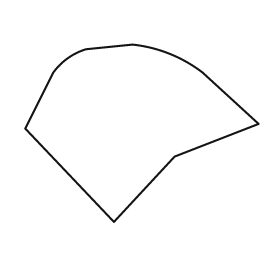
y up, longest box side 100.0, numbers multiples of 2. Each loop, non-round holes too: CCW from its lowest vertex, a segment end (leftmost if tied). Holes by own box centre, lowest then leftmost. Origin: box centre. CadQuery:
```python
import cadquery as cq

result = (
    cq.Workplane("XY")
    .moveTo(-12.0, -38.0)
    .lineTo(14.0, -10.0)
    .lineTo(50.0, 4.0)
    .lineTo(26.0, 26.0)
    .threePointArc((12.0, 34.0), (-4.0, 38.0))
    .lineTo(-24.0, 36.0)
    .threePointArc((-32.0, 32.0), (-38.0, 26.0))
    .lineTo(-50.0, 2.0)
    .close()
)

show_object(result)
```